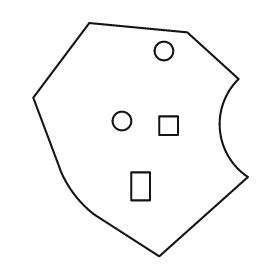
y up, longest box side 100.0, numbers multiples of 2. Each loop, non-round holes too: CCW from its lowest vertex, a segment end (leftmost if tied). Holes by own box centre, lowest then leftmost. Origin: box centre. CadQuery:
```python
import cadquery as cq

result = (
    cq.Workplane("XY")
    .moveTo(8.0, -50.0)
    .lineTo(46.0, -16.0)
    .threePointArc((34.0, 4.0), (42.0, 26.0))
    .lineTo(20.0, 46.0)
    .lineTo(-22.0, 50.0)
    .lineTo(-46.0, 18.0)
    .lineTo(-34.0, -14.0)
    .threePointArc((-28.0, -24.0), (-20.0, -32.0))
    .close()
    .moveTo(-4.0, -26.0)
    .lineTo(4.0, -26.0)
    .lineTo(4.0, -14.0)
    .lineTo(-4.0, -14.0)
    .close()
    .moveTo(8.0, 2.0)
    .lineTo(16.0, 2.0)
    .lineTo(16.0, 10.0)
    .lineTo(8.0, 10.0)
    .close()
    .moveTo(-8.0, 8.0)
    .circle(4.0)
    .moveTo(10.0, 38.0)
    .circle(4.0)
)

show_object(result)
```